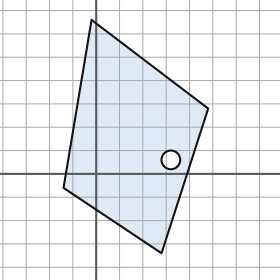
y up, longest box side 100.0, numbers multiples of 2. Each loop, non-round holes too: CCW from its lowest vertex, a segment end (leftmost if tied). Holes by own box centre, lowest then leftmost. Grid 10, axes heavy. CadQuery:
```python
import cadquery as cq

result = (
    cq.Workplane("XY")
    .moveTo(28.0, -34.0)
    .lineTo(48.0, 28.0)
    .lineTo(-2.0, 66.0)
    .lineTo(-14.0, -6.0)
    .close()
    .moveTo(32.0, 6.0)
    .circle(4.0)
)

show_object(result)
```